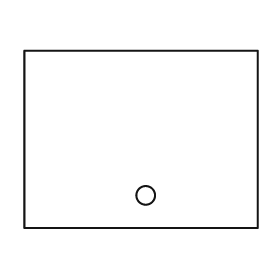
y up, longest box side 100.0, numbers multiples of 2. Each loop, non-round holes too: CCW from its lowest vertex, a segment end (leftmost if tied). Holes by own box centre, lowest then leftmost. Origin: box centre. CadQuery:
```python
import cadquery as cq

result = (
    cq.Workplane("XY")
    .moveTo(-50.0, -38.0)
    .lineTo(50.0, -38.0)
    .lineTo(50.0, 38.0)
    .lineTo(-50.0, 38.0)
    .close()
    .moveTo(2.0, -24.0)
    .circle(4.0)
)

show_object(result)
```